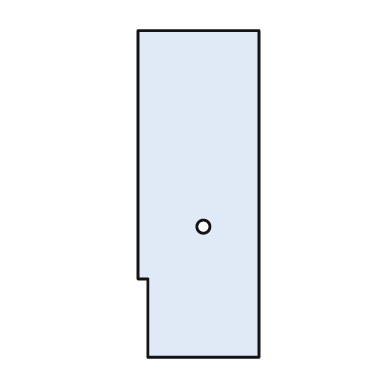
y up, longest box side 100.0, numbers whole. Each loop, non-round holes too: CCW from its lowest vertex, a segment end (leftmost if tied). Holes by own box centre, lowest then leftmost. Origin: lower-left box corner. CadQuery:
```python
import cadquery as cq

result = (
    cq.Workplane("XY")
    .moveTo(3.0, 0.0)
    .lineTo(37.0, 0.0)
    .lineTo(37.0, 100.0)
    .lineTo(0.0, 100.0)
    .lineTo(0.0, 24.0)
    .lineTo(3.0, 24.0)
    .close()
    .moveTo(20.0, 40.0)
    .circle(2.0)
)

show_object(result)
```